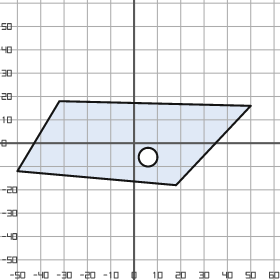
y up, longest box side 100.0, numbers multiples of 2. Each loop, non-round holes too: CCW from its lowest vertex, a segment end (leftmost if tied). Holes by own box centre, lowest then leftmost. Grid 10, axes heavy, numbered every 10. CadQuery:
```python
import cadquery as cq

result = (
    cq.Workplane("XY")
    .moveTo(18.0, -18.0)
    .lineTo(50.0, 16.0)
    .lineTo(-32.0, 18.0)
    .lineTo(-50.0, -12.0)
    .close()
    .moveTo(6.0, -6.0)
    .circle(4.0)
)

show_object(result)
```